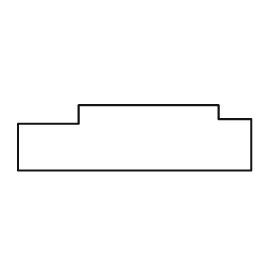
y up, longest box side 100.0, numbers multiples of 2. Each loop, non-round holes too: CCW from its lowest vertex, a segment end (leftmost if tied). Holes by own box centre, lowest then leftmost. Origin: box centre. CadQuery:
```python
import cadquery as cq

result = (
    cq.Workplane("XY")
    .moveTo(-50.0, -14.0)
    .lineTo(50.0, -14.0)
    .lineTo(50.0, 8.0)
    .lineTo(36.0, 8.0)
    .lineTo(36.0, 14.0)
    .lineTo(-24.0, 14.0)
    .lineTo(-24.0, 6.0)
    .lineTo(-50.0, 6.0)
    .close()
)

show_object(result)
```